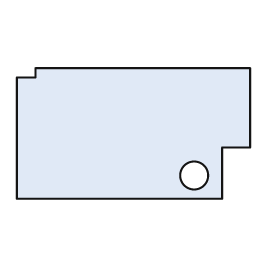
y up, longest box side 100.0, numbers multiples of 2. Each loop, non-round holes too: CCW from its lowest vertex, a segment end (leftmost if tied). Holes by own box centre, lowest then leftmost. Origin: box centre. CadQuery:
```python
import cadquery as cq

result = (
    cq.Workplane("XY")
    .moveTo(-50.0, -28.0)
    .lineTo(38.0, -28.0)
    .lineTo(38.0, -6.0)
    .lineTo(50.0, -6.0)
    .lineTo(50.0, 28.0)
    .lineTo(-42.0, 28.0)
    .lineTo(-42.0, 24.0)
    .lineTo(-50.0, 24.0)
    .close()
    .moveTo(26.0, -18.0)
    .circle(6.0)
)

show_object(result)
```